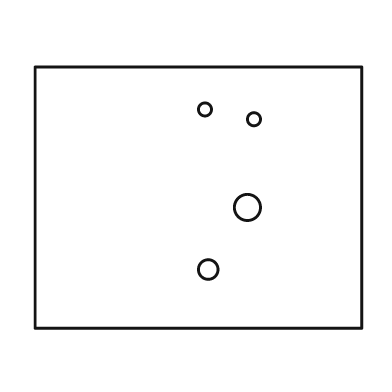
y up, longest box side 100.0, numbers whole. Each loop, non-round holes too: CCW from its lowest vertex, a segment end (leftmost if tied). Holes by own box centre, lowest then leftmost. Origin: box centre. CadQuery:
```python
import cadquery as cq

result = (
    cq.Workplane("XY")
    .moveTo(-50.0, -40.0)
    .lineTo(50.0, -40.0)
    .lineTo(50.0, 40.0)
    .lineTo(-50.0, 40.0)
    .close()
    .moveTo(3.0, -22.0)
    .circle(3.0)
    .moveTo(15.0, -3.0)
    .circle(4.0)
    .moveTo(17.0, 24.0)
    .circle(2.0)
    .moveTo(2.0, 27.0)
    .circle(2.0)
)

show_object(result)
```